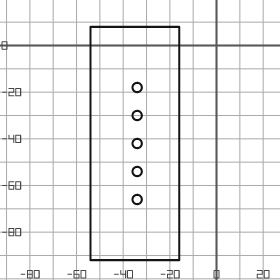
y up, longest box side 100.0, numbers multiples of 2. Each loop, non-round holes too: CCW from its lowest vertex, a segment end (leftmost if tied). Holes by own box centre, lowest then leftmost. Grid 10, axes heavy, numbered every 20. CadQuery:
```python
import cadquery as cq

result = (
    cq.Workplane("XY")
    .moveTo(-54.0, -92.0)
    .lineTo(-16.0, -92.0)
    .lineTo(-16.0, 8.0)
    .lineTo(-54.0, 8.0)
    .close()
    .moveTo(-34.0, -66.0)
    .circle(2.0)
    .moveTo(-34.0, -54.0)
    .circle(2.0)
    .moveTo(-34.0, -42.0)
    .circle(2.0)
    .moveTo(-34.0, -30.0)
    .circle(2.0)
    .moveTo(-34.0, -18.0)
    .circle(2.0)
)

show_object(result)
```